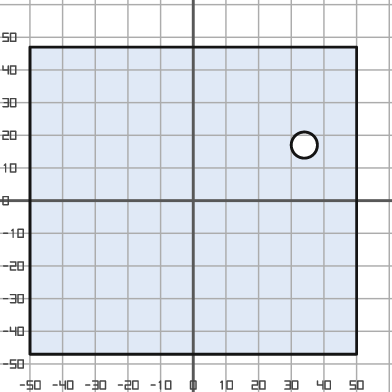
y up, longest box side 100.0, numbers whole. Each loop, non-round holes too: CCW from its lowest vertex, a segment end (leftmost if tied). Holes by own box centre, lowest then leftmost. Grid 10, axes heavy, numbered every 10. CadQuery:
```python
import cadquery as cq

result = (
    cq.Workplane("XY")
    .moveTo(-50.0, -47.0)
    .lineTo(50.0, -47.0)
    .lineTo(50.0, 47.0)
    .lineTo(-50.0, 47.0)
    .close()
    .moveTo(34.0, 17.0)
    .circle(4.0)
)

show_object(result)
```